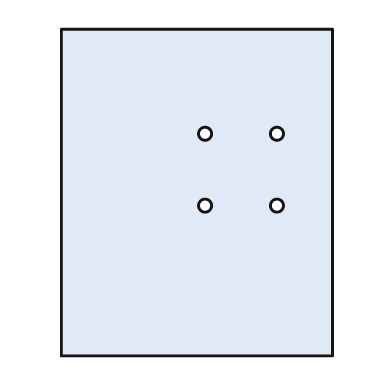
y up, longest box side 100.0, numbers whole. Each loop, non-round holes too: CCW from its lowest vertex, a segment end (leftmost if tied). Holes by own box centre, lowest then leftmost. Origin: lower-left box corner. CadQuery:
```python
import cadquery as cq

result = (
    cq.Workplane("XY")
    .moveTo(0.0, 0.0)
    .lineTo(83.0, 0.0)
    .lineTo(83.0, 100.0)
    .lineTo(0.0, 100.0)
    .close()
    .moveTo(44.0, 46.0)
    .circle(2.0)
    .moveTo(66.0, 46.0)
    .circle(2.0)
    .moveTo(44.0, 68.0)
    .circle(2.0)
    .moveTo(66.0, 68.0)
    .circle(2.0)
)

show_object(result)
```